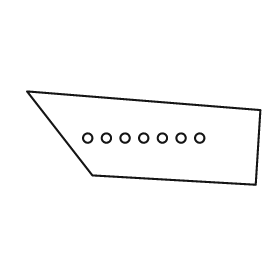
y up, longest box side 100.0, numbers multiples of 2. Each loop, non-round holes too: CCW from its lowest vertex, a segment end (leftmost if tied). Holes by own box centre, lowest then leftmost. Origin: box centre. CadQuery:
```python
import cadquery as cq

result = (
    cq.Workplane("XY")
    .moveTo(48.0, -20.0)
    .lineTo(50.0, 12.0)
    .lineTo(-50.0, 20.0)
    .lineTo(-22.0, -16.0)
    .close()
    .moveTo(-24.0, 0.0)
    .circle(2.0)
    .moveTo(-16.0, 0.0)
    .circle(2.0)
    .moveTo(-8.0, 0.0)
    .circle(2.0)
    .moveTo(0.0, 0.0)
    .circle(2.0)
    .moveTo(8.0, 0.0)
    .circle(2.0)
    .moveTo(16.0, 0.0)
    .circle(2.0)
    .moveTo(24.0, 0.0)
    .circle(2.0)
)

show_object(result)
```